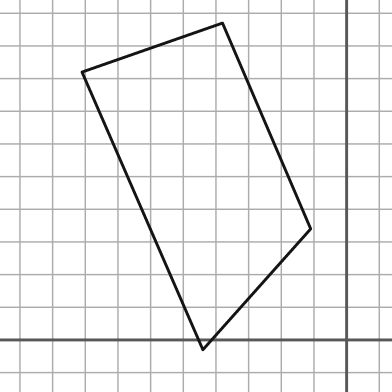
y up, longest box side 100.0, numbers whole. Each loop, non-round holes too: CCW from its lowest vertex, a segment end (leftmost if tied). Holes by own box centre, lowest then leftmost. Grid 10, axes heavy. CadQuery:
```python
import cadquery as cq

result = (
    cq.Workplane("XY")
    .moveTo(-44.0, -3.0)
    .lineTo(-11.0, 34.0)
    .lineTo(-38.0, 97.0)
    .lineTo(-81.0, 82.0)
    .close()
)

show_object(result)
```